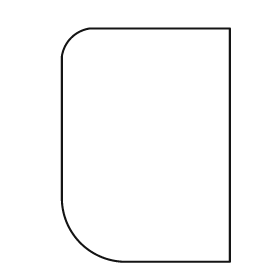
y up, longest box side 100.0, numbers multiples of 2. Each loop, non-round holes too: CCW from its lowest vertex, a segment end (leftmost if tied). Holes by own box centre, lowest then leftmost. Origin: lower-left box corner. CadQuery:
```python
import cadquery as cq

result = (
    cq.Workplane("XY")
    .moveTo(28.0, 0.0)
    .lineTo(72.0, 0.0)
    .lineTo(72.0, 100.0)
    .lineTo(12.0, 100.0)
    .threePointArc((4.0, 96.0), (0.0, 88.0))
    .lineTo(0.0, 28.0)
    .threePointArc((8.0, 8.0), (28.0, 0.0))
    .close()
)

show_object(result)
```